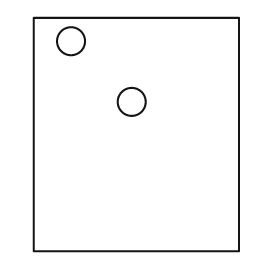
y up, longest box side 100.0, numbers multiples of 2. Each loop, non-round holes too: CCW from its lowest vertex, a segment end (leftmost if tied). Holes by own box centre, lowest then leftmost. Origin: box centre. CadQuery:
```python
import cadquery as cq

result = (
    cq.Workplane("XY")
    .moveTo(-44.0, -50.0)
    .lineTo(44.0, -50.0)
    .lineTo(44.0, 50.0)
    .lineTo(-44.0, 50.0)
    .close()
    .moveTo(-2.0, 14.0)
    .circle(6.0)
    .moveTo(-28.0, 40.0)
    .circle(6.0)
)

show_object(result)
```